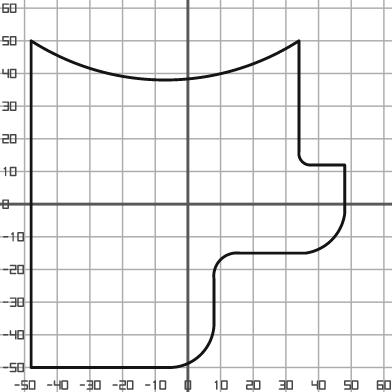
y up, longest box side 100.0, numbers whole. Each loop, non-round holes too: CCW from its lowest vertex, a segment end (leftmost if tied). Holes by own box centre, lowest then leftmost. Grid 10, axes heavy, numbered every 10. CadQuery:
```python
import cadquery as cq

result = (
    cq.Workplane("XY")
    .moveTo(-48.0, -50.0)
    .lineTo(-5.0, -50.0)
    .threePointArc((4.0, -46.0), (8.0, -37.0))
    .lineTo(8.0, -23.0)
    .threePointArc((10.0, -17.0), (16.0, -15.0))
    .lineTo(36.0, -15.0)
    .threePointArc((44.0, -11.0), (48.0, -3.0))
    .lineTo(48.0, 12.0)
    .lineTo(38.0, 12.0)
    .threePointArc((35.0, 13.0), (34.0, 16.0))
    .lineTo(34.0, 50.0)
    .threePointArc((-7.0, 38.0), (-48.0, 50.0))
    .close()
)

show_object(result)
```